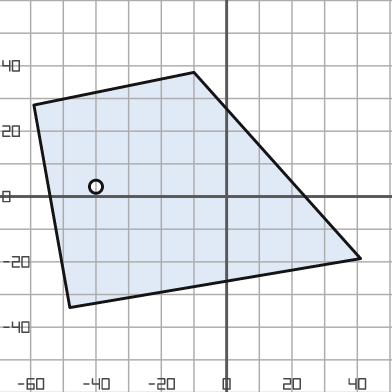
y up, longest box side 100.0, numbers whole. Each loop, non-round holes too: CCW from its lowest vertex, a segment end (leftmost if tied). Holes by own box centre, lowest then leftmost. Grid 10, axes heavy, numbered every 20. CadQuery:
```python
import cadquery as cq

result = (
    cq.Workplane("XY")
    .moveTo(-48.0, -34.0)
    .lineTo(41.0, -19.0)
    .lineTo(-10.0, 38.0)
    .lineTo(-59.0, 28.0)
    .close()
    .moveTo(-40.0, 3.0)
    .circle(2.0)
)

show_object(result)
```